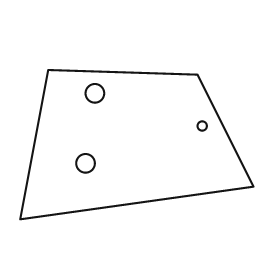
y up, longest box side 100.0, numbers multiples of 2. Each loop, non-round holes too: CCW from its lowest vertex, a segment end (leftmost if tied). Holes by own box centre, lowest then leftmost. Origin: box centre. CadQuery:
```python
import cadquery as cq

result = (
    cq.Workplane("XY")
    .moveTo(-50.0, -32.0)
    .lineTo(50.0, -18.0)
    .lineTo(26.0, 30.0)
    .lineTo(-38.0, 32.0)
    .close()
    .moveTo(-22.0, -8.0)
    .circle(4.0)
    .moveTo(28.0, 8.0)
    .circle(2.0)
    .moveTo(-18.0, 22.0)
    .circle(4.0)
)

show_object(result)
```